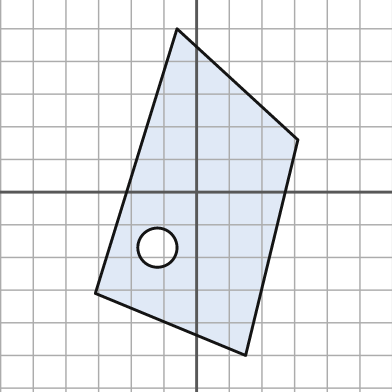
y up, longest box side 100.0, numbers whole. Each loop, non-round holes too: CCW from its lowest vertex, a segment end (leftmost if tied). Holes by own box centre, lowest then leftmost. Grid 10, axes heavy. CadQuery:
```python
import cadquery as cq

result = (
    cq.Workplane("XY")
    .moveTo(15.0, -50.0)
    .lineTo(31.0, 16.0)
    .lineTo(-6.0, 50.0)
    .lineTo(-31.0, -31.0)
    .close()
    .moveTo(-12.0, -17.0)
    .circle(6.0)
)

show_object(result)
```